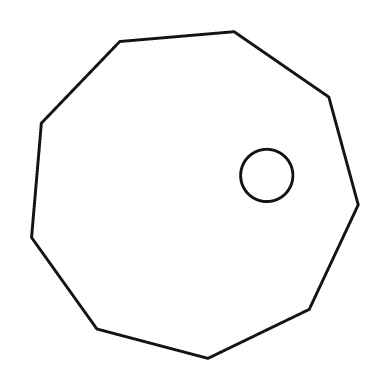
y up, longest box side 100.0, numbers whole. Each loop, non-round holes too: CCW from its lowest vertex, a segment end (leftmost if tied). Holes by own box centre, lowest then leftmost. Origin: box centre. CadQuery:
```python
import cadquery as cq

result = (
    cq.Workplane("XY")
    .moveTo(4.0, -50.0)
    .lineTo(35.0, -35.0)
    .lineTo(50.0, -3.0)
    .lineTo(41.0, 30.0)
    .lineTo(12.0, 50.0)
    .lineTo(-23.0, 47.0)
    .lineTo(-47.0, 22.0)
    .lineTo(-50.0, -13.0)
    .lineTo(-30.0, -41.0)
    .close()
    .moveTo(22.0, 6.0)
    .circle(8.0)
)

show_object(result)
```